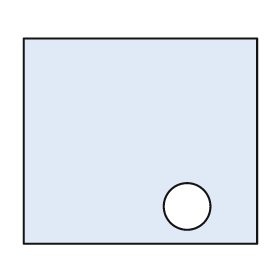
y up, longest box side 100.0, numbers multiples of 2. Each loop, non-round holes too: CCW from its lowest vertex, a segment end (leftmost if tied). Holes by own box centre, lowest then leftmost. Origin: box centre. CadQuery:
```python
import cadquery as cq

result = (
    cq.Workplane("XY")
    .moveTo(-50.0, -44.0)
    .lineTo(50.0, -44.0)
    .lineTo(50.0, 44.0)
    .lineTo(-50.0, 44.0)
    .close()
    .moveTo(20.0, -28.0)
    .circle(10.0)
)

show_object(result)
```